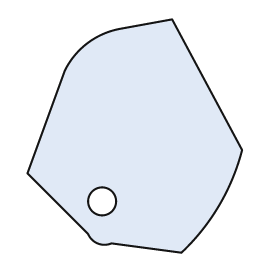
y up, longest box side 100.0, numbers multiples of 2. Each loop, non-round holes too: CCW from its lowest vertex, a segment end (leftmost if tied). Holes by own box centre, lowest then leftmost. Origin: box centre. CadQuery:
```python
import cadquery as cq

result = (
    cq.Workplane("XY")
    .moveTo(20.0, -50.0)
    .threePointArc((36.0, -30.0), (46.0, -6.0))
    .lineTo(16.0, 50.0)
    .lineTo(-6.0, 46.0)
    .threePointArc((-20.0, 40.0), (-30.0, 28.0))
    .lineTo(-46.0, -16.0)
    .lineTo(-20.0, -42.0)
    .threePointArc((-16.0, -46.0), (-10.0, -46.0))
    .close()
    .moveTo(-14.0, -28.0)
    .circle(6.0)
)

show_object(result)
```